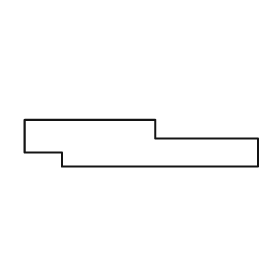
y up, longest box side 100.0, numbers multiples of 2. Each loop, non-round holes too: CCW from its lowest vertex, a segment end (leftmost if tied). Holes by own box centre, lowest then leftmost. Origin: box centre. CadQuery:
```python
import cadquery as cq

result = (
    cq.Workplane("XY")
    .moveTo(-34.0, -10.0)
    .lineTo(50.0, -10.0)
    .lineTo(50.0, 2.0)
    .lineTo(6.0, 2.0)
    .lineTo(6.0, 10.0)
    .lineTo(-50.0, 10.0)
    .lineTo(-50.0, -4.0)
    .lineTo(-34.0, -4.0)
    .close()
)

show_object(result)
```